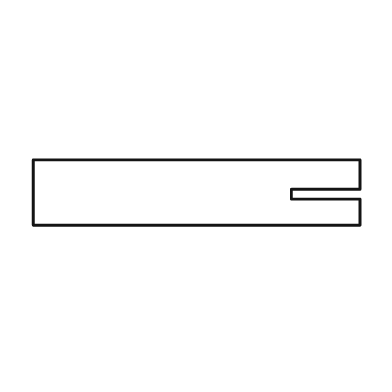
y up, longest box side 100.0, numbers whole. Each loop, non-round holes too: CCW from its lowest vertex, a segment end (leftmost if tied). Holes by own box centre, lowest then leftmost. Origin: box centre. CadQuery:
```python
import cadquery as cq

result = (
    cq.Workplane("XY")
    .moveTo(-50.0, -10.0)
    .lineTo(50.0, -10.0)
    .lineTo(50.0, -2.0)
    .lineTo(29.0, -2.0)
    .lineTo(29.0, 1.0)
    .lineTo(50.0, 1.0)
    .lineTo(50.0, 10.0)
    .lineTo(-50.0, 10.0)
    .close()
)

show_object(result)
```